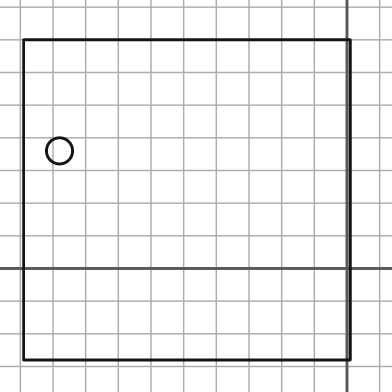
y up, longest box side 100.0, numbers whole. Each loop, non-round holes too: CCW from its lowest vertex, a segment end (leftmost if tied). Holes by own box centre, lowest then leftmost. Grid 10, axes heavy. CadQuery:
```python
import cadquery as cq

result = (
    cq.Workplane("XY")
    .moveTo(-99.0, -28.0)
    .lineTo(1.0, -28.0)
    .lineTo(1.0, 70.0)
    .lineTo(-99.0, 70.0)
    .close()
    .moveTo(-88.0, 36.0)
    .circle(4.0)
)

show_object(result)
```